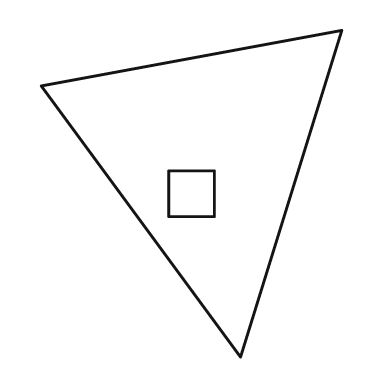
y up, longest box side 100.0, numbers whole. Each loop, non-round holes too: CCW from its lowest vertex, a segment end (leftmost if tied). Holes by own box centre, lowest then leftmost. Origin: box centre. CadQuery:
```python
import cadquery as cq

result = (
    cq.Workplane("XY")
    .moveTo(15.0, -50.0)
    .lineTo(46.0, 50.0)
    .lineTo(-46.0, 33.0)
    .close()
    .moveTo(-7.0, -7.0)
    .lineTo(7.0, -7.0)
    .lineTo(7.0, 7.0)
    .lineTo(-7.0, 7.0)
    .close()
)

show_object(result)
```